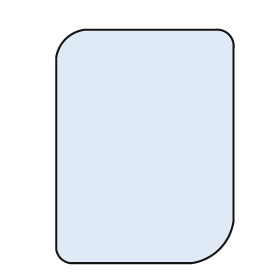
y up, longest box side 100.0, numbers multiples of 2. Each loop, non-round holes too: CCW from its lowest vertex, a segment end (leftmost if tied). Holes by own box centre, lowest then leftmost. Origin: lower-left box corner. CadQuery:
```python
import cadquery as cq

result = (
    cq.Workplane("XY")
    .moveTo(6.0, 0.0)
    .lineTo(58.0, 0.0)
    .threePointArc((70.0, 6.0), (76.0, 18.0))
    .lineTo(76.0, 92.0)
    .threePointArc((74.0, 98.0), (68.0, 100.0))
    .lineTo(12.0, 100.0)
    .threePointArc((4.0, 96.0), (0.0, 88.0))
    .lineTo(0.0, 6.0)
    .threePointArc((2.0, 2.0), (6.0, 0.0))
    .close()
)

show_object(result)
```